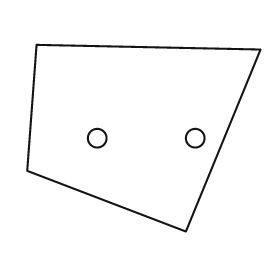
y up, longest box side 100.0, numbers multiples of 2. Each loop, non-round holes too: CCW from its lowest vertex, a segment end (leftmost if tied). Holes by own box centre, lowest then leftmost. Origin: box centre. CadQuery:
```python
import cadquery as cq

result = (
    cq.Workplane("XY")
    .moveTo(18.0, -40.0)
    .lineTo(50.0, 38.0)
    .lineTo(-46.0, 40.0)
    .lineTo(-50.0, -14.0)
    .close()
    .moveTo(-20.0, 0.0)
    .circle(4.0)
    .moveTo(22.0, 0.0)
    .circle(4.0)
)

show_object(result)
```